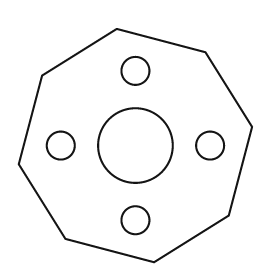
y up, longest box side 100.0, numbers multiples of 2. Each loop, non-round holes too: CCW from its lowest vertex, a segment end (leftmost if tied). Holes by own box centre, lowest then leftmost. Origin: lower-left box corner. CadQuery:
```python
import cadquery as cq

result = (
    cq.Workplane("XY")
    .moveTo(58.0, 0.0)
    .lineTo(90.0, 20.0)
    .lineTo(100.0, 58.0)
    .lineTo(80.0, 90.0)
    .lineTo(42.0, 100.0)
    .lineTo(10.0, 80.0)
    .lineTo(0.0, 42.0)
    .lineTo(20.0, 10.0)
    .close()
    .moveTo(50.0, 18.0)
    .circle(6.0)
    .moveTo(18.0, 50.0)
    .circle(6.0)
    .moveTo(50.0, 50.0)
    .circle(16.0)
    .moveTo(82.0, 50.0)
    .circle(6.0)
    .moveTo(50.0, 82.0)
    .circle(6.0)
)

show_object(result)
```